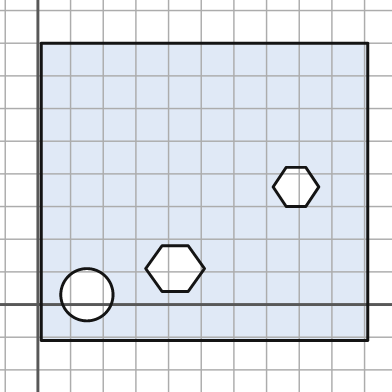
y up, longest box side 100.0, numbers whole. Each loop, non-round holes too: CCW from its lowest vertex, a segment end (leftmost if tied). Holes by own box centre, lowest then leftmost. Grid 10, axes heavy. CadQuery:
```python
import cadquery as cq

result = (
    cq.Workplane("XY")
    .moveTo(1.0, -11.0)
    .lineTo(101.0, -11.0)
    .lineTo(101.0, 80.0)
    .lineTo(1.0, 80.0)
    .close()
    .moveTo(15.0, 3.0)
    .circle(8.0)
    .moveTo(38.0, 4.0)
    .lineTo(46.0, 4.0)
    .lineTo(51.0, 11.0)
    .lineTo(46.0, 18.0)
    .lineTo(38.0, 18.0)
    .lineTo(33.0, 11.0)
    .close()
    .moveTo(76.0, 30.0)
    .lineTo(82.0, 30.0)
    .lineTo(86.0, 36.0)
    .lineTo(82.0, 42.0)
    .lineTo(76.0, 42.0)
    .lineTo(72.0, 36.0)
    .close()
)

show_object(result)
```